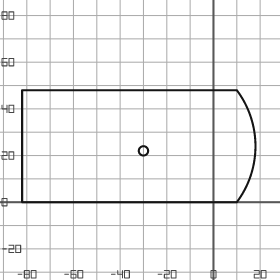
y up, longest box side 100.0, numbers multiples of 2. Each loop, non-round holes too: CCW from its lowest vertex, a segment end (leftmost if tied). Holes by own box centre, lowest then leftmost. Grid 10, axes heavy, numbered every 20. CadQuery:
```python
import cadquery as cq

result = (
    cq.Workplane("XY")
    .moveTo(-82.0, 0.0)
    .lineTo(10.0, 0.0)
    .threePointArc((18.0, 24.0), (10.0, 48.0))
    .lineTo(-82.0, 48.0)
    .close()
    .moveTo(-30.0, 22.0)
    .circle(2.0)
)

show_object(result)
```